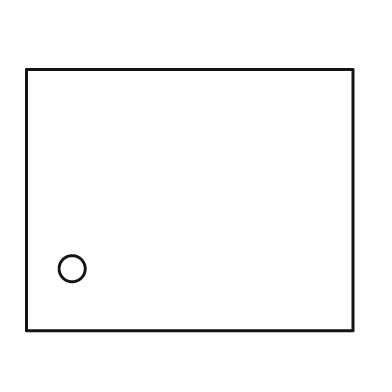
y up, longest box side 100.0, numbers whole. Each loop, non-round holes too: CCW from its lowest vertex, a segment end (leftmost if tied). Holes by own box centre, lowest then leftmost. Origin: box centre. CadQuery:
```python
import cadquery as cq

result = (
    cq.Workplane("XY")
    .moveTo(-50.0, -40.0)
    .lineTo(50.0, -40.0)
    .lineTo(50.0, 40.0)
    .lineTo(-50.0, 40.0)
    .close()
    .moveTo(-36.0, -21.0)
    .circle(4.0)
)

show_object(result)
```